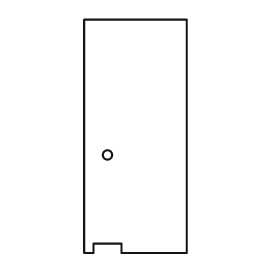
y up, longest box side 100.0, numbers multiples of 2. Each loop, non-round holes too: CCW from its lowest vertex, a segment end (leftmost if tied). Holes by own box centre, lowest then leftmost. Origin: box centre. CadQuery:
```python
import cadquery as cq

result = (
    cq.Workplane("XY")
    .moveTo(-22.0, -50.0)
    .lineTo(-18.0, -50.0)
    .lineTo(-18.0, -46.0)
    .lineTo(-6.0, -46.0)
    .lineTo(-6.0, -50.0)
    .lineTo(22.0, -50.0)
    .lineTo(22.0, 50.0)
    .lineTo(-22.0, 50.0)
    .close()
    .moveTo(-12.0, -8.0)
    .circle(2.0)
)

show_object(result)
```